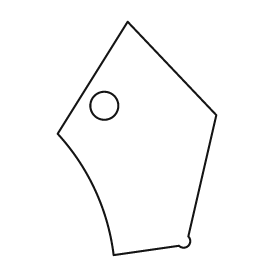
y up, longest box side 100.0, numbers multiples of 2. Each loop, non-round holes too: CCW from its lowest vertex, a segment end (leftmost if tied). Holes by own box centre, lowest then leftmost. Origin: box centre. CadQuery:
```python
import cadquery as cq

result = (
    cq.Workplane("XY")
    .moveTo(-10.0, -50.0)
    .lineTo(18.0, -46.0)
    .threePointArc((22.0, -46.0), (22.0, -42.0))
    .lineTo(34.0, 10.0)
    .lineTo(-4.0, 50.0)
    .lineTo(-34.0, 2.0)
    .threePointArc((-18.0, -22.0), (-10.0, -50.0))
    .close()
    .moveTo(-14.0, 14.0)
    .circle(6.0)
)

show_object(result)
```